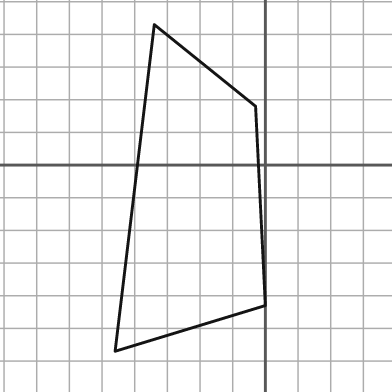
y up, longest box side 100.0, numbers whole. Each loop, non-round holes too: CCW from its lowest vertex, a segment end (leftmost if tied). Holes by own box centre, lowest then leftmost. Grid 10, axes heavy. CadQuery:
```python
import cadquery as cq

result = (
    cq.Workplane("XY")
    .moveTo(-46.0, -57.0)
    .lineTo(0.0, -43.0)
    .lineTo(-3.0, 18.0)
    .lineTo(-34.0, 43.0)
    .close()
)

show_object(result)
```